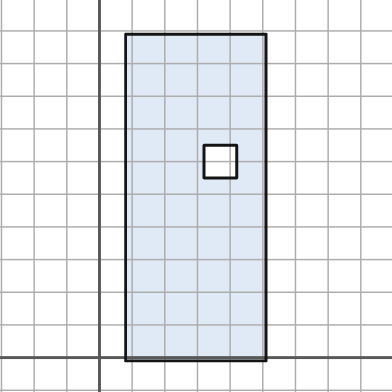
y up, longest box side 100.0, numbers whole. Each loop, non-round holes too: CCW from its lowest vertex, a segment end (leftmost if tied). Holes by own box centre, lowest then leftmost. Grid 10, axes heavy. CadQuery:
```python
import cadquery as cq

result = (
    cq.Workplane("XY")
    .moveTo(8.0, -1.0)
    .lineTo(51.0, -1.0)
    .lineTo(51.0, 99.0)
    .lineTo(8.0, 99.0)
    .close()
    .moveTo(32.0, 55.0)
    .lineTo(42.0, 55.0)
    .lineTo(42.0, 65.0)
    .lineTo(32.0, 65.0)
    .close()
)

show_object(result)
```